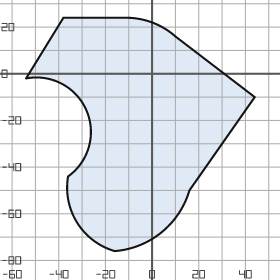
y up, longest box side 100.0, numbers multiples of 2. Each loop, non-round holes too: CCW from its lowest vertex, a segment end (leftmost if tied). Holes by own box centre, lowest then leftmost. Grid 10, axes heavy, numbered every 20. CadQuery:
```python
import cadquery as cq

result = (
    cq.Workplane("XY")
    .moveTo(-16.0, -76.0)
    .threePointArc((4.0, -68.0), (16.0, -50.0))
    .lineTo(44.0, -10.0)
    .lineTo(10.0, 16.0)
    .threePointArc((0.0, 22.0), (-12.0, 24.0))
    .lineTo(-38.0, 24.0)
    .lineTo(-54.0, -2.0)
    .threePointArc((-28.0, -16.0), (-36.0, -44.0))
    .threePointArc((-32.0, -64.0), (-16.0, -76.0))
    .close()
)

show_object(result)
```